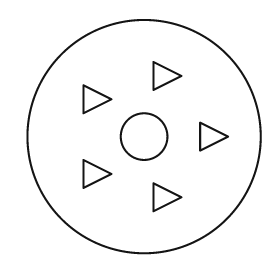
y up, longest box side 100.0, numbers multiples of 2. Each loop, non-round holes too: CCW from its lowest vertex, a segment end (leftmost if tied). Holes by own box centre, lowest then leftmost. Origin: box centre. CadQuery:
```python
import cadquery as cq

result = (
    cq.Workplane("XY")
    .moveTo(0.0, 0.0)
    .circle(50.0)
    .moveTo(4.0, -32.0)
    .lineTo(16.0, -26.0)
    .lineTo(4.0, -20.0)
    .close()
    .moveTo(-26.0, -22.0)
    .lineTo(-14.0, -16.0)
    .lineTo(-26.0, -10.0)
    .close()
    .moveTo(0.0, 0.0)
    .circle(10.0)
    .moveTo(24.0, -6.0)
    .lineTo(36.0, 0.0)
    .lineTo(24.0, 6.0)
    .close()
    .moveTo(-26.0, 10.0)
    .lineTo(-14.0, 16.0)
    .lineTo(-26.0, 22.0)
    .close()
    .moveTo(4.0, 20.0)
    .lineTo(16.0, 26.0)
    .lineTo(4.0, 32.0)
    .close()
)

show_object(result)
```